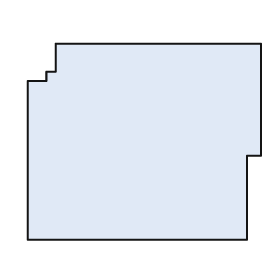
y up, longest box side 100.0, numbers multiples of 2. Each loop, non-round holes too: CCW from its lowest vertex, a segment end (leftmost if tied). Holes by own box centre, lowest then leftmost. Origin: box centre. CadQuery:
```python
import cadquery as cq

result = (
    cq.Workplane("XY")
    .moveTo(-50.0, -42.0)
    .lineTo(44.0, -42.0)
    .lineTo(44.0, -6.0)
    .lineTo(50.0, -6.0)
    .lineTo(50.0, 42.0)
    .lineTo(-38.0, 42.0)
    .lineTo(-38.0, 30.0)
    .lineTo(-42.0, 30.0)
    .lineTo(-42.0, 26.0)
    .lineTo(-50.0, 26.0)
    .close()
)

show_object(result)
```